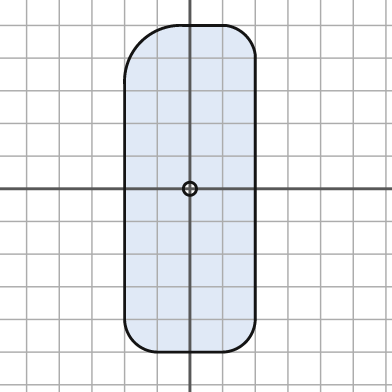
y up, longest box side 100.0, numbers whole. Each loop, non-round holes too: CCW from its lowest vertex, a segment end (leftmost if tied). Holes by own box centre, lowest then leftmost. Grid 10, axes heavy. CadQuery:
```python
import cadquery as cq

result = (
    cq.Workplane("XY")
    .moveTo(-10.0, -50.0)
    .lineTo(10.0, -50.0)
    .threePointArc((17.0, -47.0), (20.0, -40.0))
    .lineTo(20.0, 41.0)
    .threePointArc((17.0, 47.0), (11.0, 50.0))
    .lineTo(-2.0, 50.0)
    .threePointArc((-15.0, 45.0), (-20.0, 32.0))
    .lineTo(-20.0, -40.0)
    .threePointArc((-17.0, -47.0), (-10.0, -50.0))
    .close()
    .moveTo(0.0, 0.0)
    .circle(2.0)
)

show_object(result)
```